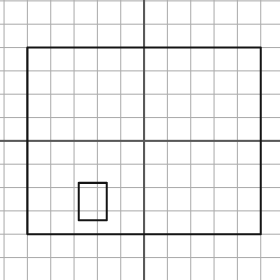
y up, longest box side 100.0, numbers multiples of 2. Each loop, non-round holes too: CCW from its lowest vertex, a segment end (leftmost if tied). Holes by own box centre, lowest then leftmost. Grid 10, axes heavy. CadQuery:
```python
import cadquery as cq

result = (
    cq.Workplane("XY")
    .moveTo(-50.0, -40.0)
    .lineTo(50.0, -40.0)
    .lineTo(50.0, 40.0)
    .lineTo(-50.0, 40.0)
    .close()
    .moveTo(-28.0, -34.0)
    .lineTo(-16.0, -34.0)
    .lineTo(-16.0, -18.0)
    .lineTo(-28.0, -18.0)
    .close()
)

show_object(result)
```